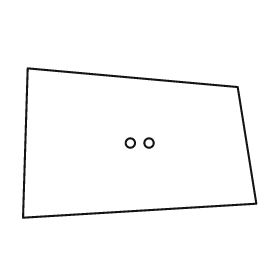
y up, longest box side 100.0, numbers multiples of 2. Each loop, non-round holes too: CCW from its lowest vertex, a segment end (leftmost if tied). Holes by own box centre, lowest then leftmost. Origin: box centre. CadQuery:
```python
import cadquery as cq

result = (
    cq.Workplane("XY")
    .moveTo(-50.0, -32.0)
    .lineTo(50.0, -26.0)
    .lineTo(42.0, 24.0)
    .lineTo(-48.0, 32.0)
    .close()
    .moveTo(-4.0, 0.0)
    .circle(2.0)
    .moveTo(4.0, 0.0)
    .circle(2.0)
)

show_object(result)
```